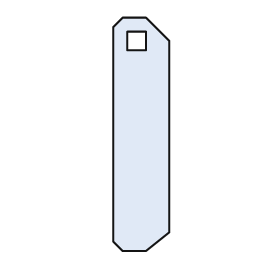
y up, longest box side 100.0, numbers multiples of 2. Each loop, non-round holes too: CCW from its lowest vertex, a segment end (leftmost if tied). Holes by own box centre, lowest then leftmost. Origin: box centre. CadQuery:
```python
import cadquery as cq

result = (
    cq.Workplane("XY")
    .moveTo(-8.0, -50.0)
    .lineTo(2.0, -50.0)
    .lineTo(12.0, -42.0)
    .lineTo(12.0, 40.0)
    .lineTo(2.0, 50.0)
    .lineTo(-8.0, 50.0)
    .lineTo(-12.0, 46.0)
    .lineTo(-12.0, -46.0)
    .close()
    .moveTo(-6.0, 36.0)
    .lineTo(2.0, 36.0)
    .lineTo(2.0, 44.0)
    .lineTo(-6.0, 44.0)
    .close()
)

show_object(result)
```